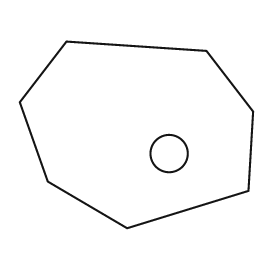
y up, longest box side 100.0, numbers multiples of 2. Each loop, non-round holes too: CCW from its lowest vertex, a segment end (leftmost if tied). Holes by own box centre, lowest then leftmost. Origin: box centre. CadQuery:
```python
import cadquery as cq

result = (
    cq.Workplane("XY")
    .moveTo(-4.0, -40.0)
    .lineTo(48.0, -24.0)
    .lineTo(50.0, 10.0)
    .lineTo(30.0, 36.0)
    .lineTo(-30.0, 40.0)
    .lineTo(-50.0, 14.0)
    .lineTo(-38.0, -20.0)
    .close()
    .moveTo(14.0, -8.0)
    .circle(8.0)
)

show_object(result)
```